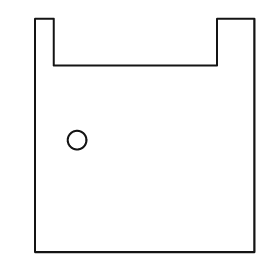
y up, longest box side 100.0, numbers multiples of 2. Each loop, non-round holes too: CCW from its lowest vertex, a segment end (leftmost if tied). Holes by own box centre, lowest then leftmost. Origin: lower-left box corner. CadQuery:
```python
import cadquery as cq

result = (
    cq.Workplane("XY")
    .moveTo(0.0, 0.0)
    .lineTo(94.0, 0.0)
    .lineTo(94.0, 100.0)
    .lineTo(78.0, 100.0)
    .lineTo(78.0, 80.0)
    .lineTo(8.0, 80.0)
    .lineTo(8.0, 100.0)
    .lineTo(0.0, 100.0)
    .close()
    .moveTo(18.0, 48.0)
    .circle(4.0)
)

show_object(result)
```